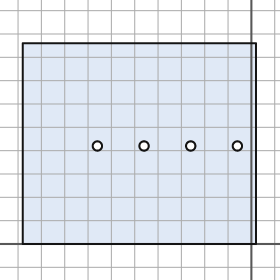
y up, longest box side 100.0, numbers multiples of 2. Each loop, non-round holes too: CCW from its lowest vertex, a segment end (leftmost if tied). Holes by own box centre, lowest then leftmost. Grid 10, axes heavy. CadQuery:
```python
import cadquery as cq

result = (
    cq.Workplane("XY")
    .moveTo(-98.0, 0.0)
    .lineTo(2.0, 0.0)
    .lineTo(2.0, 86.0)
    .lineTo(-98.0, 86.0)
    .close()
    .moveTo(-66.0, 42.0)
    .circle(2.0)
    .moveTo(-46.0, 42.0)
    .circle(2.0)
    .moveTo(-26.0, 42.0)
    .circle(2.0)
    .moveTo(-6.0, 42.0)
    .circle(2.0)
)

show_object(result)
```